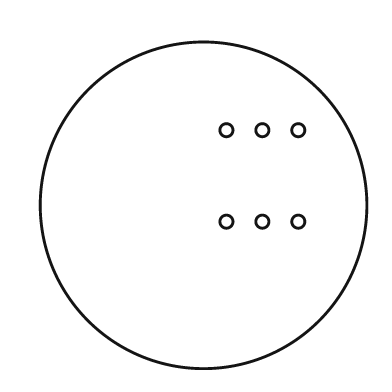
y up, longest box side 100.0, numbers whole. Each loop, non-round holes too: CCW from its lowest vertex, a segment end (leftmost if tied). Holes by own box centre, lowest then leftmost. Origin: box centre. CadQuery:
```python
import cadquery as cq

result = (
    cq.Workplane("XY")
    .moveTo(0.0, 0.0)
    .circle(50.0)
    .moveTo(7.0, -5.0)
    .circle(2.0)
    .moveTo(18.0, -5.0)
    .circle(2.0)
    .moveTo(29.0, -5.0)
    .circle(2.0)
    .moveTo(7.0, 23.0)
    .circle(2.0)
    .moveTo(18.0, 23.0)
    .circle(2.0)
    .moveTo(29.0, 23.0)
    .circle(2.0)
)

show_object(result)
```